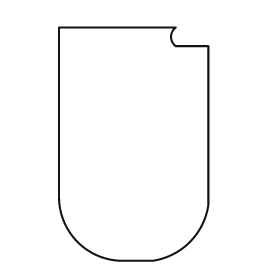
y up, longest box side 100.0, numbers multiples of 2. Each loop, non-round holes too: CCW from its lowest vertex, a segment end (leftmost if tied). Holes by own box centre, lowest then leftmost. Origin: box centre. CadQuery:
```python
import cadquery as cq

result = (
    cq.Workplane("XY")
    .moveTo(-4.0, -50.0)
    .lineTo(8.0, -50.0)
    .threePointArc((24.0, -42.0), (32.0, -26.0))
    .lineTo(32.0, 42.0)
    .lineTo(18.0, 42.0)
    .threePointArc((16.0, 46.0), (18.0, 50.0))
    .lineTo(-32.0, 50.0)
    .lineTo(-32.0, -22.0)
    .threePointArc((-24.0, -42.0), (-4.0, -50.0))
    .close()
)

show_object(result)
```